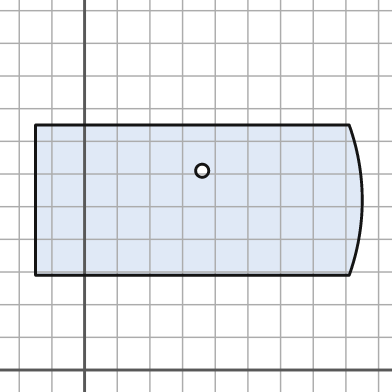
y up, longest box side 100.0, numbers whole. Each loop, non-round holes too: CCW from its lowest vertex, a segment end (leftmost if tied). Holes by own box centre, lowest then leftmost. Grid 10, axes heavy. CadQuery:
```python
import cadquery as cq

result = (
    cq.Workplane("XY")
    .moveTo(-15.0, 29.0)
    .lineTo(81.0, 29.0)
    .threePointArc((85.0, 52.0), (81.0, 75.0))
    .lineTo(-15.0, 75.0)
    .close()
    .moveTo(36.0, 61.0)
    .circle(2.0)
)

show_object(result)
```